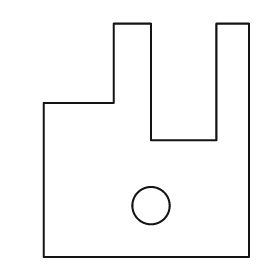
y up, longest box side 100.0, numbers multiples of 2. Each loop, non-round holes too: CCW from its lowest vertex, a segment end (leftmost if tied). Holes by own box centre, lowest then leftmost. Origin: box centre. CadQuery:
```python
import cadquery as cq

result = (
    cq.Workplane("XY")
    .moveTo(-44.0, -50.0)
    .lineTo(44.0, -50.0)
    .lineTo(44.0, 50.0)
    .lineTo(30.0, 50.0)
    .lineTo(30.0, 0.0)
    .lineTo(2.0, 0.0)
    .lineTo(2.0, 50.0)
    .lineTo(-14.0, 50.0)
    .lineTo(-14.0, 16.0)
    .lineTo(-44.0, 16.0)
    .close()
    .moveTo(2.0, -28.0)
    .circle(8.0)
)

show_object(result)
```